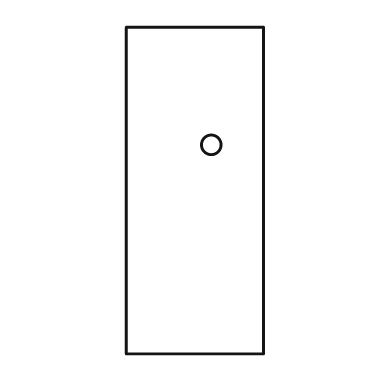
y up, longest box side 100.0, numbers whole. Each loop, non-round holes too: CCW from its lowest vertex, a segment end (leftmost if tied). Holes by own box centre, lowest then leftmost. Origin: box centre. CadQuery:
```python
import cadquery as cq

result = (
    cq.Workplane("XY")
    .moveTo(-21.0, -50.0)
    .lineTo(21.0, -50.0)
    .lineTo(21.0, 50.0)
    .lineTo(-21.0, 50.0)
    .close()
    .moveTo(5.0, 14.0)
    .circle(3.0)
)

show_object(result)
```